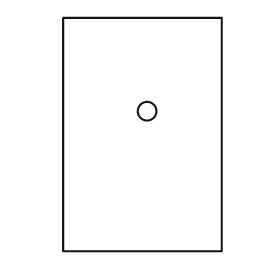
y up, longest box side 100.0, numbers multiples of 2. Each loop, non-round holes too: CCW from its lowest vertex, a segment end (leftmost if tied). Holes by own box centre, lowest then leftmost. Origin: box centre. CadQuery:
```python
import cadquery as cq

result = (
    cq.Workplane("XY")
    .moveTo(-34.0, -50.0)
    .lineTo(34.0, -50.0)
    .lineTo(34.0, 50.0)
    .lineTo(-34.0, 50.0)
    .close()
    .moveTo(2.0, 10.0)
    .circle(4.0)
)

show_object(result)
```